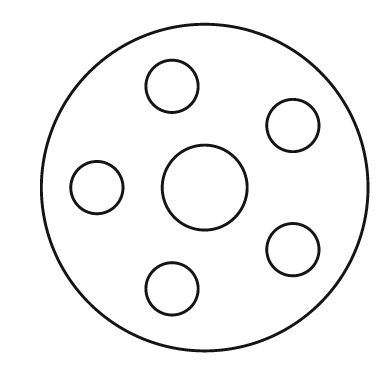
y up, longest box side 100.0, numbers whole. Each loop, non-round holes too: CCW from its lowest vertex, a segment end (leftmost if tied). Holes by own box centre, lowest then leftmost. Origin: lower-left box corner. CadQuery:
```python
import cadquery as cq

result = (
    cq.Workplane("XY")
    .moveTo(50.0, 50.0)
    .circle(50.0)
    .moveTo(40.0, 19.0)
    .circle(8.0)
    .moveTo(77.0, 31.0)
    .circle(8.0)
    .moveTo(17.0, 50.0)
    .circle(8.0)
    .moveTo(50.0, 50.0)
    .circle(13.0)
    .moveTo(77.0, 69.0)
    .circle(8.0)
    .moveTo(40.0, 81.0)
    .circle(8.0)
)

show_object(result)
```